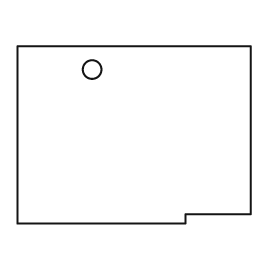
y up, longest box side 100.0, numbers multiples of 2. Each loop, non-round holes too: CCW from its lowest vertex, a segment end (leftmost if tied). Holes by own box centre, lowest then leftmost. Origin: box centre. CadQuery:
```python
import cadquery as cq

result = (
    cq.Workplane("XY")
    .moveTo(-50.0, -38.0)
    .lineTo(22.0, -38.0)
    .lineTo(22.0, -34.0)
    .lineTo(50.0, -34.0)
    .lineTo(50.0, 38.0)
    .lineTo(-50.0, 38.0)
    .close()
    .moveTo(-18.0, 28.0)
    .circle(4.0)
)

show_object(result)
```